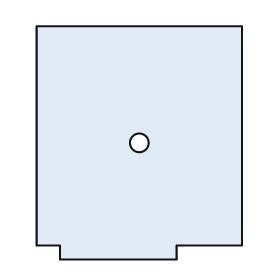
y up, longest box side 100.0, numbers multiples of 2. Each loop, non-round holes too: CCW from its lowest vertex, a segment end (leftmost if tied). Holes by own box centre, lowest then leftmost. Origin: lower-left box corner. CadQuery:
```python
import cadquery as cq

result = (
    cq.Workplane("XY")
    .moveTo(10.0, 0.0)
    .lineTo(60.0, 0.0)
    .lineTo(60.0, 6.0)
    .lineTo(88.0, 6.0)
    .lineTo(88.0, 100.0)
    .lineTo(0.0, 100.0)
    .lineTo(0.0, 6.0)
    .lineTo(10.0, 6.0)
    .close()
    .moveTo(44.0, 50.0)
    .circle(4.0)
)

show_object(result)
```